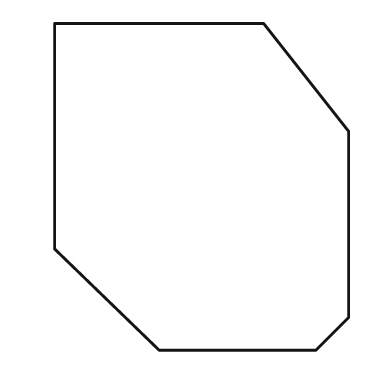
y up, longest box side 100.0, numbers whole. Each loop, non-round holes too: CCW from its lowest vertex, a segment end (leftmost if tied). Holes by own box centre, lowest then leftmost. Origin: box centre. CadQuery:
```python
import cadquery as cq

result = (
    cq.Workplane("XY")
    .moveTo(-13.0, -50.0)
    .lineTo(35.0, -50.0)
    .lineTo(45.0, -40.0)
    .lineTo(45.0, 17.0)
    .lineTo(19.0, 50.0)
    .lineTo(-45.0, 50.0)
    .lineTo(-45.0, -19.0)
    .close()
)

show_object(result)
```